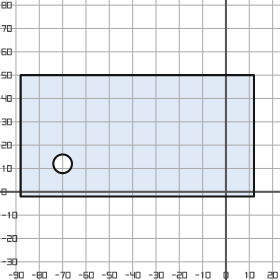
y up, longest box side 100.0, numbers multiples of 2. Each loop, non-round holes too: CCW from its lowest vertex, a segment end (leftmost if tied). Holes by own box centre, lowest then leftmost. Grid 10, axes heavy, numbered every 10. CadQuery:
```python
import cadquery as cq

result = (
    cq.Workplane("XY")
    .moveTo(-88.0, -2.0)
    .lineTo(12.0, -2.0)
    .lineTo(12.0, 50.0)
    .lineTo(-88.0, 50.0)
    .close()
    .moveTo(-70.0, 12.0)
    .circle(4.0)
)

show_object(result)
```